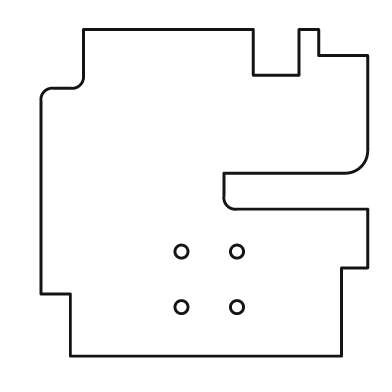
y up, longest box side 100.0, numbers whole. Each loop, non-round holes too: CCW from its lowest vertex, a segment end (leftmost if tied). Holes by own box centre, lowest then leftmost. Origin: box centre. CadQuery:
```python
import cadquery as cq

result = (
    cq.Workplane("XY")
    .moveTo(-41.0, -50.0)
    .lineTo(42.0, -50.0)
    .lineTo(42.0, -23.0)
    .lineTo(50.0, -23.0)
    .lineTo(50.0, -5.0)
    .lineTo(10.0, -5.0)
    .threePointArc((7.0, -4.0), (6.0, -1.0))
    .lineTo(6.0, 6.0)
    .lineTo(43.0, 6.0)
    .threePointArc((48.0, 8.0), (50.0, 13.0))
    .lineTo(50.0, 42.0)
    .lineTo(35.0, 42.0)
    .lineTo(35.0, 50.0)
    .lineTo(29.0, 50.0)
    .lineTo(29.0, 36.0)
    .lineTo(15.0, 36.0)
    .lineTo(15.0, 50.0)
    .lineTo(-37.0, 50.0)
    .lineTo(-37.0, 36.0)
    .threePointArc((-38.0, 33.0), (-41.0, 32.0))
    .lineTo(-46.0, 32.0)
    .threePointArc((-49.0, 31.0), (-50.0, 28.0))
    .lineTo(-50.0, -31.0)
    .lineTo(-41.0, -31.0)
    .close()
    .moveTo(-7.0, -35.0)
    .circle(2.0)
    .moveTo(10.0, -35.0)
    .circle(2.0)
    .moveTo(-7.0, -18.0)
    .circle(2.0)
    .moveTo(10.0, -18.0)
    .circle(2.0)
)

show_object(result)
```